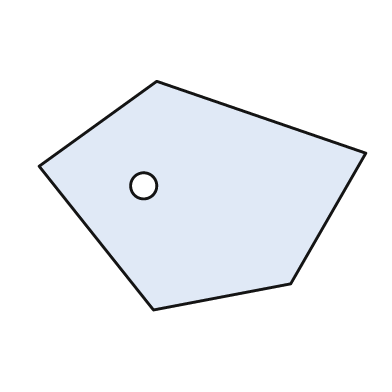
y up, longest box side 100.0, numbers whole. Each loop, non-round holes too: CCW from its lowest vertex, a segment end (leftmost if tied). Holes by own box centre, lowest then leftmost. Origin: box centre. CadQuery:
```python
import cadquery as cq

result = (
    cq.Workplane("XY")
    .moveTo(-15.0, -35.0)
    .lineTo(27.0, -27.0)
    .lineTo(50.0, 13.0)
    .lineTo(-14.0, 35.0)
    .lineTo(-50.0, 9.0)
    .close()
    .moveTo(-18.0, 3.0)
    .circle(4.0)
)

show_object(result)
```